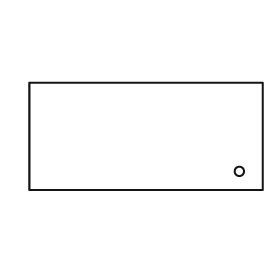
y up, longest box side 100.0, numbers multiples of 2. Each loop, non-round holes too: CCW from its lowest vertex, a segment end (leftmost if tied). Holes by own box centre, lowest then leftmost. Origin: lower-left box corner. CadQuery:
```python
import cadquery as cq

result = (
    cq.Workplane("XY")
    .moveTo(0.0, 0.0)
    .lineTo(100.0, 0.0)
    .lineTo(100.0, 46.0)
    .lineTo(0.0, 46.0)
    .close()
    .moveTo(90.0, 8.0)
    .circle(2.0)
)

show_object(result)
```